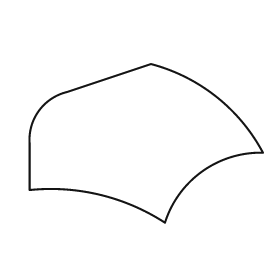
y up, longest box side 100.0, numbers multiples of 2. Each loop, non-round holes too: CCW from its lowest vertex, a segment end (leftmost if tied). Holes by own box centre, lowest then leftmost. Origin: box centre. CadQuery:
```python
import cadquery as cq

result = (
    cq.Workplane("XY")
    .moveTo(8.0, -34.0)
    .threePointArc((24.0, -12.0), (50.0, -4.0))
    .threePointArc((30.0, 20.0), (2.0, 34.0))
    .lineTo(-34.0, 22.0)
    .threePointArc((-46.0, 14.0), (-50.0, 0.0))
    .lineTo(-50.0, -20.0)
    .threePointArc((-20.0, -22.0), (8.0, -34.0))
    .close()
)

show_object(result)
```